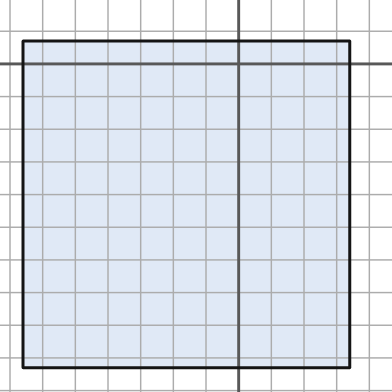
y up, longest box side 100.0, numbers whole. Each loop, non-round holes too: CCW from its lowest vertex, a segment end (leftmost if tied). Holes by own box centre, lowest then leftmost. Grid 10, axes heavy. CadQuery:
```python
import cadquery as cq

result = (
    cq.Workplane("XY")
    .moveTo(-66.0, -93.0)
    .lineTo(34.0, -93.0)
    .lineTo(34.0, 7.0)
    .lineTo(-66.0, 7.0)
    .close()
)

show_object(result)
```